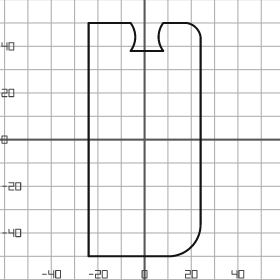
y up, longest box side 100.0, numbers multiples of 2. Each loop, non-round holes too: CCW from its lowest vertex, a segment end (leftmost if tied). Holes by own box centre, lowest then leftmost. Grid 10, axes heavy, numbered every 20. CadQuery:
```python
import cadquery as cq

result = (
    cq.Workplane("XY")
    .moveTo(-24.0, -50.0)
    .lineTo(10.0, -50.0)
    .threePointArc((20.0, -46.0), (24.0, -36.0))
    .lineTo(24.0, 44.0)
    .threePointArc((22.0, 48.0), (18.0, 50.0))
    .lineTo(8.0, 50.0)
    .threePointArc((6.0, 44.0), (8.0, 38.0))
    .lineTo(-6.0, 38.0)
    .threePointArc((-4.0, 44.0), (-6.0, 50.0))
    .lineTo(-24.0, 50.0)
    .close()
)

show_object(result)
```